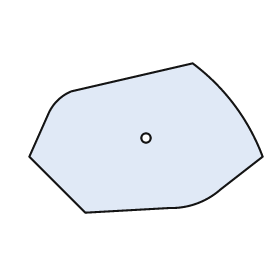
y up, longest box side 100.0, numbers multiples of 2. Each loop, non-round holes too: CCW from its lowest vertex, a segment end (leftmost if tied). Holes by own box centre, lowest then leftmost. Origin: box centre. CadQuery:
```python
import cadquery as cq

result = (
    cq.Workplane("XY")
    .moveTo(-26.0, -32.0)
    .lineTo(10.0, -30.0)
    .threePointArc((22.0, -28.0), (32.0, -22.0))
    .lineTo(50.0, -8.0)
    .threePointArc((38.0, 14.0), (20.0, 32.0))
    .lineTo(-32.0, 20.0)
    .threePointArc((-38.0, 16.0), (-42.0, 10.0))
    .lineTo(-50.0, -8.0)
    .close()
    .moveTo(0.0, 0.0)
    .circle(2.0)
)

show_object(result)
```